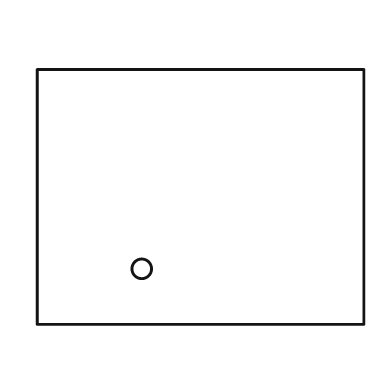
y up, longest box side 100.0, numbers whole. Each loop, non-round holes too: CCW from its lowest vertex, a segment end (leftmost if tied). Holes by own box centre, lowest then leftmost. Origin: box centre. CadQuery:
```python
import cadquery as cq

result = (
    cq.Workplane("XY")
    .moveTo(-50.0, -39.0)
    .lineTo(50.0, -39.0)
    .lineTo(50.0, 39.0)
    .lineTo(-50.0, 39.0)
    .close()
    .moveTo(-18.0, -22.0)
    .circle(3.0)
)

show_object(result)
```